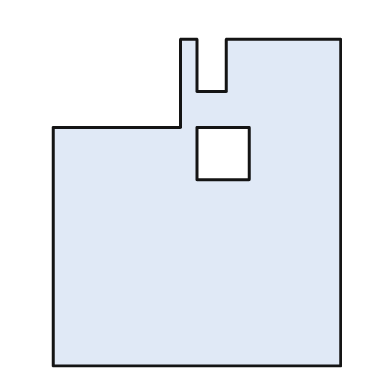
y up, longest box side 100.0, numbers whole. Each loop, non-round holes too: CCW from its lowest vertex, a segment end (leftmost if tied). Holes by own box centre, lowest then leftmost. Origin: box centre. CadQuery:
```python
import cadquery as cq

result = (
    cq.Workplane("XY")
    .moveTo(-44.0, -50.0)
    .lineTo(44.0, -50.0)
    .lineTo(44.0, 50.0)
    .lineTo(9.0, 50.0)
    .lineTo(9.0, 34.0)
    .lineTo(0.0, 34.0)
    .lineTo(0.0, 50.0)
    .lineTo(-5.0, 50.0)
    .lineTo(-5.0, 23.0)
    .lineTo(-44.0, 23.0)
    .close()
    .moveTo(0.0, 7.0)
    .lineTo(16.0, 7.0)
    .lineTo(16.0, 23.0)
    .lineTo(0.0, 23.0)
    .close()
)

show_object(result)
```